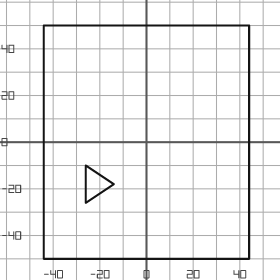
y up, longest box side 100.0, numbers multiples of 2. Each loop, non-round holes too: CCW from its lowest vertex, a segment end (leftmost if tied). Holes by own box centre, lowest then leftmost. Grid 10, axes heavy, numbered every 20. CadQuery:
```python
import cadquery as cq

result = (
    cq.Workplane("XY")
    .moveTo(-44.0, -50.0)
    .lineTo(44.0, -50.0)
    .lineTo(44.0, 50.0)
    .lineTo(-44.0, 50.0)
    .close()
    .moveTo(-26.0, -26.0)
    .lineTo(-14.0, -18.0)
    .lineTo(-26.0, -10.0)
    .close()
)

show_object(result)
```